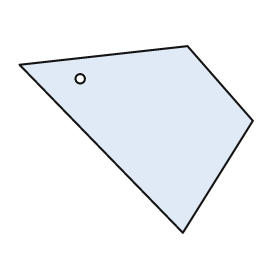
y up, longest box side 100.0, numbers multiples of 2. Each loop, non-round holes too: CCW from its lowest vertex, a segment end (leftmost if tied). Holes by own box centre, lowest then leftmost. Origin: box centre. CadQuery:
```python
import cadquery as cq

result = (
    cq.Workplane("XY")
    .moveTo(20.0, -40.0)
    .lineTo(50.0, 8.0)
    .lineTo(22.0, 40.0)
    .lineTo(-50.0, 32.0)
    .close()
    .moveTo(-24.0, 26.0)
    .circle(2.0)
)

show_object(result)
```